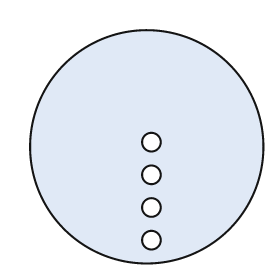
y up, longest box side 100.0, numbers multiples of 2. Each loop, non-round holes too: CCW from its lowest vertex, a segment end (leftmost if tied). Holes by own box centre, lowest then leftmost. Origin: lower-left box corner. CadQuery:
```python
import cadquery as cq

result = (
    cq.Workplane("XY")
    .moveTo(50.0, 50.0)
    .circle(50.0)
    .moveTo(52.0, 10.0)
    .circle(4.0)
    .moveTo(52.0, 24.0)
    .circle(4.0)
    .moveTo(52.0, 38.0)
    .circle(4.0)
    .moveTo(52.0, 52.0)
    .circle(4.0)
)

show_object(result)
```